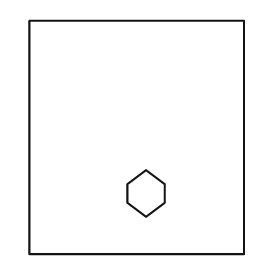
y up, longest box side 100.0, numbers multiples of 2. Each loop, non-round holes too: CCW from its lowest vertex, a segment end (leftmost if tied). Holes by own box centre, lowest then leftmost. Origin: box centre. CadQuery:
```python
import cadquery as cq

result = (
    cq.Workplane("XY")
    .moveTo(-46.0, -50.0)
    .lineTo(46.0, -50.0)
    .lineTo(46.0, 50.0)
    .lineTo(-46.0, 50.0)
    .close()
    .moveTo(4.0, -34.0)
    .lineTo(12.0, -28.0)
    .lineTo(12.0, -20.0)
    .lineTo(4.0, -14.0)
    .lineTo(-4.0, -20.0)
    .lineTo(-4.0, -28.0)
    .close()
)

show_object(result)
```